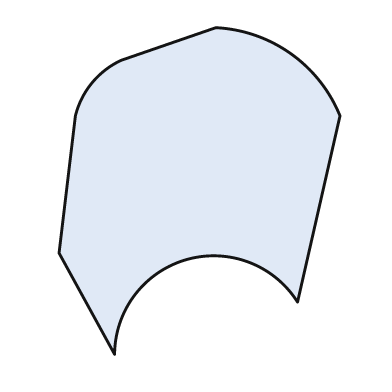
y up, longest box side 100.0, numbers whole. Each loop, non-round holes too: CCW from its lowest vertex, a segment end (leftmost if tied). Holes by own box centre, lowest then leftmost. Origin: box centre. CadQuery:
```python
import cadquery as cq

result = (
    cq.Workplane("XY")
    .moveTo(-26.0, -50.0)
    .threePointArc((-4.0, -21.0), (30.0, -34.0))
    .lineTo(43.0, 23.0)
    .threePointArc((28.0, 42.0), (5.0, 50.0))
    .lineTo(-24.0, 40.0)
    .threePointArc((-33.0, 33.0), (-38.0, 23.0))
    .lineTo(-43.0, -19.0)
    .close()
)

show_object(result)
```